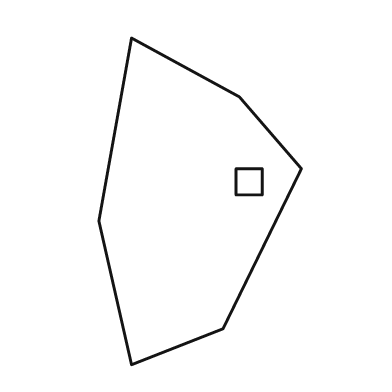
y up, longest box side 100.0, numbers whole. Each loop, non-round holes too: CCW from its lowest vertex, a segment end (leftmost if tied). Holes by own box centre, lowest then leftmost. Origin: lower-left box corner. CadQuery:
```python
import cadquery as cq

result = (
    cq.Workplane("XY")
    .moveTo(10.0, 0.0)
    .lineTo(38.0, 11.0)
    .lineTo(62.0, 60.0)
    .lineTo(43.0, 82.0)
    .lineTo(10.0, 100.0)
    .lineTo(0.0, 44.0)
    .close()
    .moveTo(42.0, 52.0)
    .lineTo(50.0, 52.0)
    .lineTo(50.0, 60.0)
    .lineTo(42.0, 60.0)
    .close()
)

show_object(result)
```